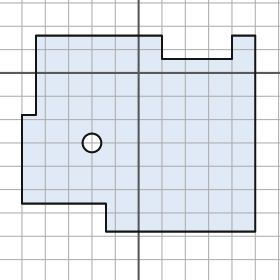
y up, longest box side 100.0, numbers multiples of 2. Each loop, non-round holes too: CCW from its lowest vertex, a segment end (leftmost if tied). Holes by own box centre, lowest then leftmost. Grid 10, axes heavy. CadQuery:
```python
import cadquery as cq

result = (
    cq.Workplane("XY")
    .moveTo(-14.0, -68.0)
    .lineTo(50.0, -68.0)
    .lineTo(50.0, 16.0)
    .lineTo(40.0, 16.0)
    .lineTo(40.0, 6.0)
    .lineTo(10.0, 6.0)
    .lineTo(10.0, 16.0)
    .lineTo(-44.0, 16.0)
    .lineTo(-44.0, -18.0)
    .lineTo(-50.0, -18.0)
    .lineTo(-50.0, -56.0)
    .lineTo(-14.0, -56.0)
    .close()
    .moveTo(-20.0, -30.0)
    .circle(4.0)
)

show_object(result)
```